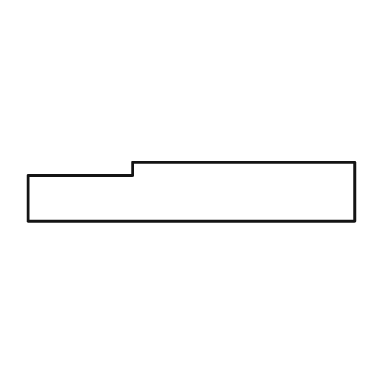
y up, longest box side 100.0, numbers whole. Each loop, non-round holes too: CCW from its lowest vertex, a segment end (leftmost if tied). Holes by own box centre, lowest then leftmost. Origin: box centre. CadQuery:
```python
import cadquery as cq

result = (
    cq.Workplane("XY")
    .moveTo(-50.0, -9.0)
    .lineTo(50.0, -9.0)
    .lineTo(50.0, 9.0)
    .lineTo(-18.0, 9.0)
    .lineTo(-18.0, 5.0)
    .lineTo(-50.0, 5.0)
    .close()
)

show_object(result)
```